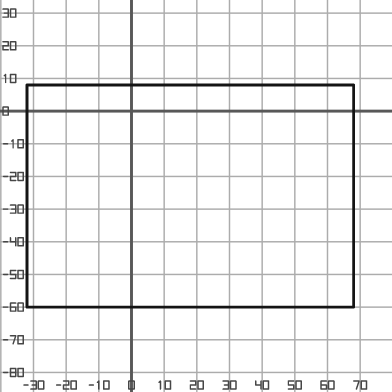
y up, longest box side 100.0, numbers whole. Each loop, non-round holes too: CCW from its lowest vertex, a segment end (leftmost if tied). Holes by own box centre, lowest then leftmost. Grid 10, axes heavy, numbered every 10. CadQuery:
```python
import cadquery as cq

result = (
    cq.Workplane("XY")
    .moveTo(-32.0, -60.0)
    .lineTo(68.0, -60.0)
    .lineTo(68.0, 8.0)
    .lineTo(-32.0, 8.0)
    .close()
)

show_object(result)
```